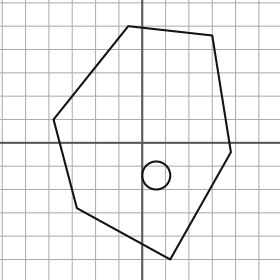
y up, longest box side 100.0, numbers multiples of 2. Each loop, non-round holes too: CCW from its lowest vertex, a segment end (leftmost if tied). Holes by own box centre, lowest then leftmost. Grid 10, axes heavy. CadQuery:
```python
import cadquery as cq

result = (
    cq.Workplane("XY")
    .moveTo(12.0, -50.0)
    .lineTo(38.0, -4.0)
    .lineTo(30.0, 46.0)
    .lineTo(-6.0, 50.0)
    .lineTo(-38.0, 10.0)
    .lineTo(-28.0, -28.0)
    .close()
    .moveTo(6.0, -14.0)
    .circle(6.0)
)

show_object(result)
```